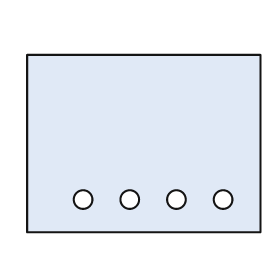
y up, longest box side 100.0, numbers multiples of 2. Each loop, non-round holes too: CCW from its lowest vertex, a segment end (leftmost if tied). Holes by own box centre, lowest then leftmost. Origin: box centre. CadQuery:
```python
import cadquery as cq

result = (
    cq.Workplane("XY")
    .moveTo(-50.0, -38.0)
    .lineTo(50.0, -38.0)
    .lineTo(50.0, 38.0)
    .lineTo(-50.0, 38.0)
    .close()
    .moveTo(-26.0, -24.0)
    .circle(4.0)
    .moveTo(-6.0, -24.0)
    .circle(4.0)
    .moveTo(14.0, -24.0)
    .circle(4.0)
    .moveTo(34.0, -24.0)
    .circle(4.0)
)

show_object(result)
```